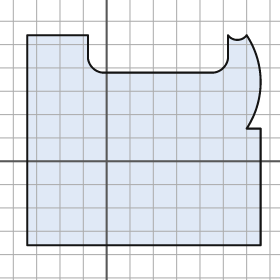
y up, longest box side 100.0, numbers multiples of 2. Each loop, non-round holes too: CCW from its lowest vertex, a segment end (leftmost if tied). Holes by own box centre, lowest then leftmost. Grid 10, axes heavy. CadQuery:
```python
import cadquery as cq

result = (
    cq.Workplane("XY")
    .moveTo(-34.0, -36.0)
    .lineTo(66.0, -36.0)
    .lineTo(66.0, 14.0)
    .lineTo(60.0, 14.0)
    .threePointArc((66.0, 34.0), (60.0, 54.0))
    .threePointArc((56.0, 52.0), (52.0, 54.0))
    .lineTo(52.0, 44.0)
    .threePointArc((50.0, 40.0), (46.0, 38.0))
    .lineTo(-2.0, 38.0)
    .threePointArc((-6.0, 40.0), (-8.0, 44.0))
    .lineTo(-8.0, 54.0)
    .lineTo(-34.0, 54.0)
    .close()
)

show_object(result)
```